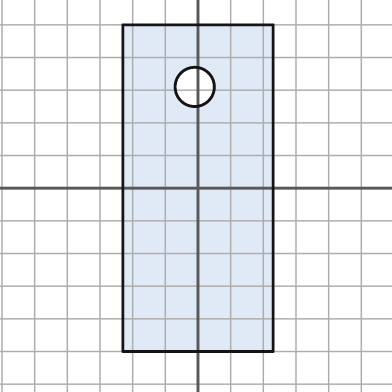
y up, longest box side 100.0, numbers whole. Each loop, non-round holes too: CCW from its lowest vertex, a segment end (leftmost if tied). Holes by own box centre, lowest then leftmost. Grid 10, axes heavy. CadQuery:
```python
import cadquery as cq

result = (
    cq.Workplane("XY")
    .moveTo(-23.0, -50.0)
    .lineTo(23.0, -50.0)
    .lineTo(23.0, 50.0)
    .lineTo(-23.0, 50.0)
    .close()
    .moveTo(-1.0, 31.0)
    .circle(6.0)
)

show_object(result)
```